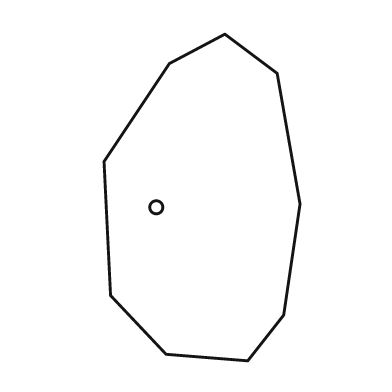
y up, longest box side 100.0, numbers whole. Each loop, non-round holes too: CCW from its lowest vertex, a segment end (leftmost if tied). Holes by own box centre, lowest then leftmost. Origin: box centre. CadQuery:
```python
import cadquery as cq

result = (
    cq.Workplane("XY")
    .moveTo(14.0, -50.0)
    .lineTo(25.0, -36.0)
    .lineTo(30.0, -2.0)
    .lineTo(23.0, 38.0)
    .lineTo(7.0, 50.0)
    .lineTo(-10.0, 41.0)
    .lineTo(-30.0, 11.0)
    .lineTo(-28.0, -30.0)
    .lineTo(-11.0, -48.0)
    .close()
    .moveTo(-14.0, -3.0)
    .circle(2.0)
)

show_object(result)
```